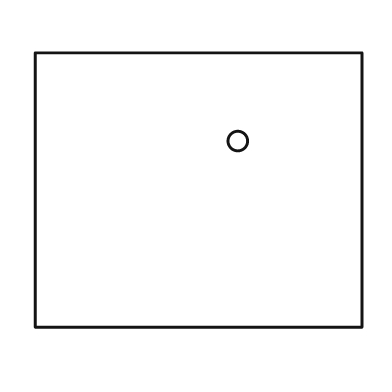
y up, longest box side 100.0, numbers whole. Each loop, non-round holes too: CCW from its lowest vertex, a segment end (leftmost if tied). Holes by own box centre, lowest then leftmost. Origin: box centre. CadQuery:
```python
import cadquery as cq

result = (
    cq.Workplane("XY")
    .moveTo(-50.0, -42.0)
    .lineTo(50.0, -42.0)
    .lineTo(50.0, 42.0)
    .lineTo(-50.0, 42.0)
    .close()
    .moveTo(12.0, 15.0)
    .circle(3.0)
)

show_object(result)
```